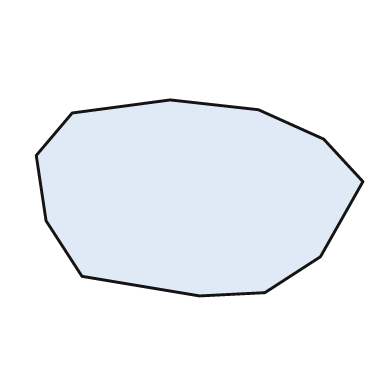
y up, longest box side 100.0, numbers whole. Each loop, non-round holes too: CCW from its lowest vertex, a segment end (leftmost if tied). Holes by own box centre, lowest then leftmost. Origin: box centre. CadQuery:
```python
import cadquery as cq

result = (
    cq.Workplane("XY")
    .moveTo(0.0, -30.0)
    .lineTo(20.0, -29.0)
    .lineTo(37.0, -18.0)
    .lineTo(50.0, 5.0)
    .lineTo(38.0, 18.0)
    .lineTo(18.0, 27.0)
    .lineTo(-9.0, 30.0)
    .lineTo(-39.0, 26.0)
    .lineTo(-50.0, 13.0)
    .lineTo(-47.0, -7.0)
    .lineTo(-36.0, -24.0)
    .close()
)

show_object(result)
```